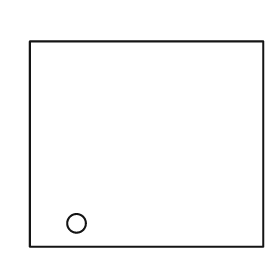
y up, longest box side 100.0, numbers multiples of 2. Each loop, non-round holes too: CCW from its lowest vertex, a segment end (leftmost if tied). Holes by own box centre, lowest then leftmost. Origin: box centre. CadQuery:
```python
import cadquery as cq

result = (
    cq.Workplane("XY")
    .moveTo(-50.0, -44.0)
    .lineTo(50.0, -44.0)
    .lineTo(50.0, 44.0)
    .lineTo(-50.0, 44.0)
    .close()
    .moveTo(-30.0, -34.0)
    .circle(4.0)
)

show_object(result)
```